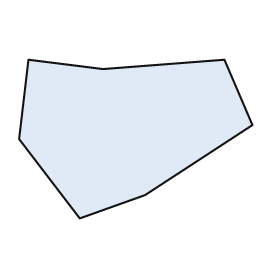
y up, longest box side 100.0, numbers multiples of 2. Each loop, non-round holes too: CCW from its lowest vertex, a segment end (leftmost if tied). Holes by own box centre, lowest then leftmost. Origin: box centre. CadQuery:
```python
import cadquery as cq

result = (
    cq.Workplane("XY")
    .moveTo(-24.0, -34.0)
    .lineTo(4.0, -24.0)
    .lineTo(50.0, 6.0)
    .lineTo(38.0, 34.0)
    .lineTo(-14.0, 30.0)
    .lineTo(-46.0, 34.0)
    .lineTo(-50.0, 0.0)
    .close()
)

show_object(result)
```